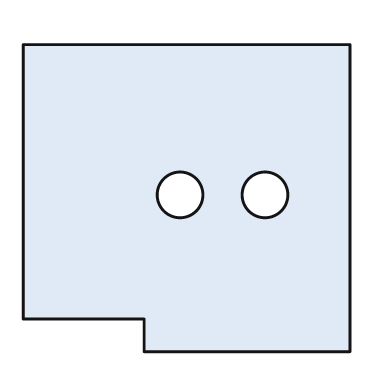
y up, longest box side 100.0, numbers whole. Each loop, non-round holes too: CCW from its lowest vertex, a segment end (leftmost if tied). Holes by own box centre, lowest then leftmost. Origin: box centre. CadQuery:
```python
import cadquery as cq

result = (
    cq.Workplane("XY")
    .moveTo(-13.0, -47.0)
    .lineTo(50.0, -47.0)
    .lineTo(50.0, 47.0)
    .lineTo(-50.0, 47.0)
    .lineTo(-50.0, -37.0)
    .lineTo(-13.0, -37.0)
    .close()
    .moveTo(-2.0, 1.0)
    .circle(7.0)
    .moveTo(24.0, 1.0)
    .circle(7.0)
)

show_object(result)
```